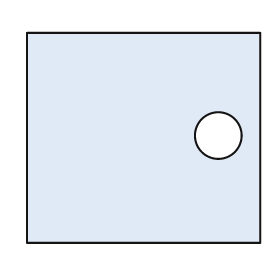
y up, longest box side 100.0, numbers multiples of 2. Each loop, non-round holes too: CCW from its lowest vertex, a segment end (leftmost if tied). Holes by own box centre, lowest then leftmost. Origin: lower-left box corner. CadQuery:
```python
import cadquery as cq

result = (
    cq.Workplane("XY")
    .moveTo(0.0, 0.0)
    .lineTo(100.0, 0.0)
    .lineTo(100.0, 90.0)
    .lineTo(0.0, 90.0)
    .close()
    .moveTo(82.0, 46.0)
    .circle(10.0)
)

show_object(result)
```